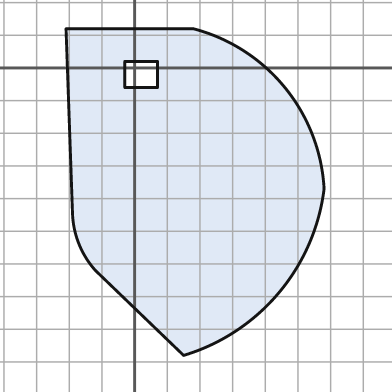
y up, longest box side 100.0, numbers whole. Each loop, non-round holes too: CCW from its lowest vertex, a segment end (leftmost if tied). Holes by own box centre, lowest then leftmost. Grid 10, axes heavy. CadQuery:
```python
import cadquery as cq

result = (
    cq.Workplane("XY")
    .moveTo(15.0, -88.0)
    .threePointArc((44.0, -69.0), (58.0, -37.0))
    .threePointArc((46.0, -6.0), (18.0, 12.0))
    .lineTo(-21.0, 12.0)
    .lineTo(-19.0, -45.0)
    .threePointArc((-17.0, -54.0), (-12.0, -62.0))
    .close()
    .moveTo(-3.0, -6.0)
    .lineTo(7.0, -6.0)
    .lineTo(7.0, 2.0)
    .lineTo(-3.0, 2.0)
    .close()
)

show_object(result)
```